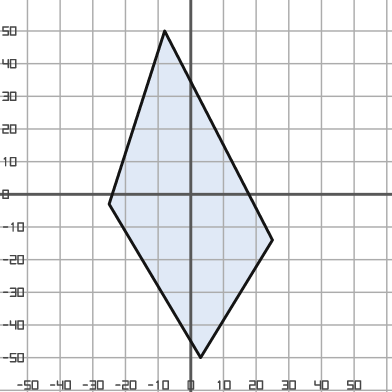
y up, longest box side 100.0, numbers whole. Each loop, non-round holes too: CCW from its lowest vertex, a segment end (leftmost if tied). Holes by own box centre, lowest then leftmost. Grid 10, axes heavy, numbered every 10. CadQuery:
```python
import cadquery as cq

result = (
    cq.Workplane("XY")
    .moveTo(3.0, -50.0)
    .lineTo(25.0, -14.0)
    .lineTo(-8.0, 50.0)
    .lineTo(-25.0, -3.0)
    .close()
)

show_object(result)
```